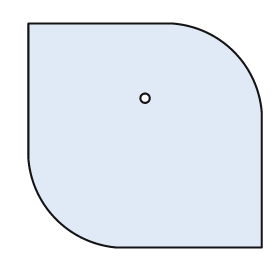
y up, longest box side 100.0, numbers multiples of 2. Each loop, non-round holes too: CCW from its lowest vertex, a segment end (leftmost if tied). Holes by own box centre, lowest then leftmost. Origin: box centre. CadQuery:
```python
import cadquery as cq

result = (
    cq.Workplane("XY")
    .moveTo(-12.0, -48.0)
    .lineTo(50.0, -48.0)
    .lineTo(50.0, 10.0)
    .threePointArc((38.0, 36.0), (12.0, 48.0))
    .lineTo(-50.0, 48.0)
    .lineTo(-50.0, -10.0)
    .threePointArc((-38.0, -36.0), (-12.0, -48.0))
    .close()
    .moveTo(0.0, 16.0)
    .circle(2.0)
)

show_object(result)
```